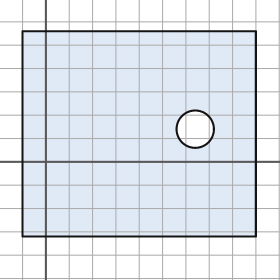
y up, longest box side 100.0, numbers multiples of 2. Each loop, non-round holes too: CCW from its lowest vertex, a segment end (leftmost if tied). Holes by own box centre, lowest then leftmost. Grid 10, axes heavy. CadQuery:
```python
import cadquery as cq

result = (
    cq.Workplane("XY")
    .moveTo(-10.0, -32.0)
    .lineTo(90.0, -32.0)
    .lineTo(90.0, 56.0)
    .lineTo(-10.0, 56.0)
    .close()
    .moveTo(64.0, 14.0)
    .circle(8.0)
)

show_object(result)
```